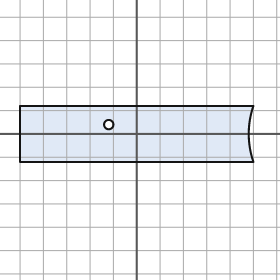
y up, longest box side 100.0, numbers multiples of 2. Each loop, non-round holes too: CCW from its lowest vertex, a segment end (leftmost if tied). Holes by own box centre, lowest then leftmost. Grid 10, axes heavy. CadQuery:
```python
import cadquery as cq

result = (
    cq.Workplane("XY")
    .moveTo(-50.0, -12.0)
    .lineTo(50.0, -12.0)
    .threePointArc((48.0, 0.0), (50.0, 12.0))
    .lineTo(-50.0, 12.0)
    .close()
    .moveTo(-12.0, 4.0)
    .circle(2.0)
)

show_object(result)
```